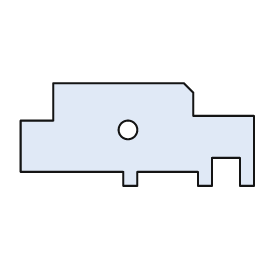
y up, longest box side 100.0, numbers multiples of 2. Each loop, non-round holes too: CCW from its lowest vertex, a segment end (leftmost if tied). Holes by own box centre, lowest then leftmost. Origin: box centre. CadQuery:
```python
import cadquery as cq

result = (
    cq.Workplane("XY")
    .moveTo(-6.0, -22.0)
    .lineTo(0.0, -22.0)
    .lineTo(0.0, -16.0)
    .lineTo(26.0, -16.0)
    .lineTo(26.0, -22.0)
    .lineTo(32.0, -22.0)
    .lineTo(32.0, -10.0)
    .lineTo(44.0, -10.0)
    .lineTo(44.0, -22.0)
    .lineTo(50.0, -22.0)
    .lineTo(50.0, 8.0)
    .lineTo(24.0, 8.0)
    .lineTo(24.0, 18.0)
    .lineTo(20.0, 22.0)
    .lineTo(-36.0, 22.0)
    .lineTo(-36.0, 6.0)
    .lineTo(-50.0, 6.0)
    .lineTo(-50.0, -16.0)
    .lineTo(-6.0, -16.0)
    .close()
    .moveTo(-4.0, 2.0)
    .circle(4.0)
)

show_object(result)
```